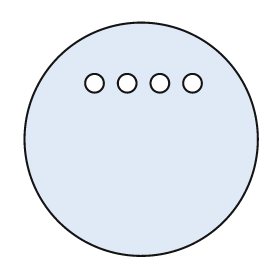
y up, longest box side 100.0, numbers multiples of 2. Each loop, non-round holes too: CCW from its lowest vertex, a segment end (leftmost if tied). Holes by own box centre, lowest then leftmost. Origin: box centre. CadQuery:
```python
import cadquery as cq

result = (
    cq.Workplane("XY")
    .moveTo(0.0, 0.0)
    .circle(50.0)
    .moveTo(-20.0, 24.0)
    .circle(4.0)
    .moveTo(-6.0, 24.0)
    .circle(4.0)
    .moveTo(8.0, 24.0)
    .circle(4.0)
    .moveTo(22.0, 24.0)
    .circle(4.0)
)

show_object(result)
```